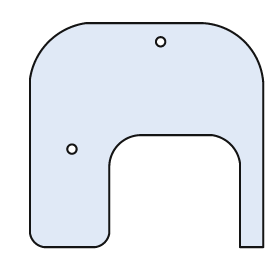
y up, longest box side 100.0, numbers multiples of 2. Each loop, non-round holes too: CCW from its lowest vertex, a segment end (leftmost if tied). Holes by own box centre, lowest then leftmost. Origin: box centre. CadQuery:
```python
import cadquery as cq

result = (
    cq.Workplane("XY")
    .moveTo(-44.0, -48.0)
    .lineTo(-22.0, -48.0)
    .threePointArc((-18.0, -46.0), (-16.0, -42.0))
    .lineTo(-16.0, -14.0)
    .threePointArc((-12.0, -4.0), (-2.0, 0.0))
    .lineTo(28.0, 0.0)
    .threePointArc((36.0, -4.0), (40.0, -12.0))
    .lineTo(40.0, -48.0)
    .lineTo(50.0, -48.0)
    .lineTo(50.0, 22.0)
    .threePointArc((42.0, 40.0), (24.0, 48.0))
    .lineTo(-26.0, 48.0)
    .threePointArc((-42.0, 40.0), (-50.0, 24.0))
    .lineTo(-50.0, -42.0)
    .threePointArc((-48.0, -46.0), (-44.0, -48.0))
    .close()
    .moveTo(-32.0, -6.0)
    .circle(2.0)
    .moveTo(6.0, 40.0)
    .circle(2.0)
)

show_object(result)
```